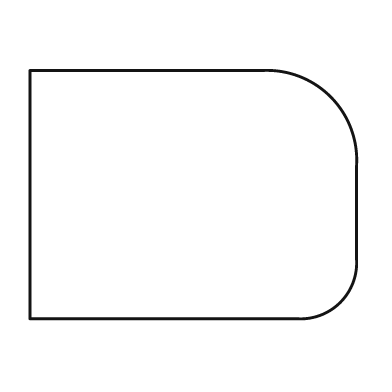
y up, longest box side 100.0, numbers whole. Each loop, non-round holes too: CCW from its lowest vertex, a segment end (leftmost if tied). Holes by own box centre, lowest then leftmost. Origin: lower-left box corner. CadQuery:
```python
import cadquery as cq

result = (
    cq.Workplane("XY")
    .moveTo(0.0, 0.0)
    .lineTo(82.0, 0.0)
    .threePointArc((95.0, 5.0), (100.0, 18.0))
    .lineTo(100.0, 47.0)
    .threePointArc((92.0, 68.0), (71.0, 76.0))
    .lineTo(0.0, 76.0)
    .close()
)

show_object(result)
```